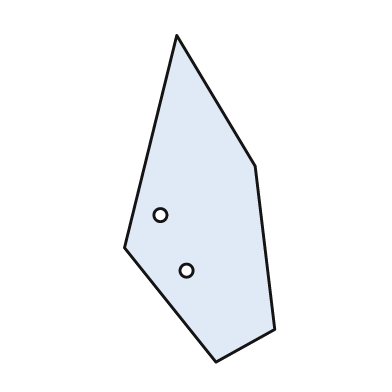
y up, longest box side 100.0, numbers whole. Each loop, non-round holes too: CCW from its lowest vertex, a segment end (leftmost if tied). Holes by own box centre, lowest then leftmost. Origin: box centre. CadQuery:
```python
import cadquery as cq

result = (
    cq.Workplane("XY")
    .moveTo(5.0, -50.0)
    .lineTo(23.0, -40.0)
    .lineTo(17.0, 10.0)
    .lineTo(-7.0, 50.0)
    .lineTo(-23.0, -15.0)
    .close()
    .moveTo(-4.0, -22.0)
    .circle(2.0)
    .moveTo(-12.0, -5.0)
    .circle(2.0)
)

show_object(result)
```